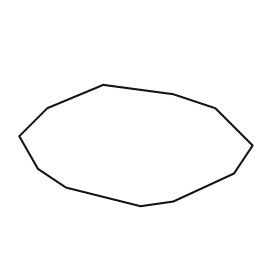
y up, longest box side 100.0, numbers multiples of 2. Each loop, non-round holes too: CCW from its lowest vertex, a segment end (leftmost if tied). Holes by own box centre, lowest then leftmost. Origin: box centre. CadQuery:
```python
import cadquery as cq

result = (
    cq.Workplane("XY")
    .moveTo(2.0, -26.0)
    .lineTo(16.0, -24.0)
    .lineTo(42.0, -12.0)
    .lineTo(50.0, 0.0)
    .lineTo(34.0, 16.0)
    .lineTo(16.0, 22.0)
    .lineTo(-14.0, 26.0)
    .lineTo(-38.0, 16.0)
    .lineTo(-50.0, 4.0)
    .lineTo(-42.0, -10.0)
    .lineTo(-30.0, -18.0)
    .close()
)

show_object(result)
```